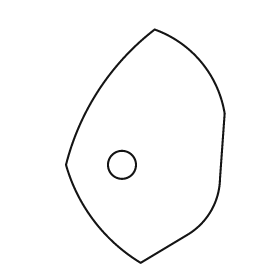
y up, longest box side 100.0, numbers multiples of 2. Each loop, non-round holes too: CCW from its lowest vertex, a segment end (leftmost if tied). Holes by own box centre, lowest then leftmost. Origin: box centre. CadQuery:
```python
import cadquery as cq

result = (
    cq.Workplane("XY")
    .moveTo(-2.0, -50.0)
    .lineTo(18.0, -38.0)
    .threePointArc((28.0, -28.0), (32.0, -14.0))
    .lineTo(34.0, 14.0)
    .threePointArc((24.0, 36.0), (4.0, 50.0))
    .threePointArc((-20.0, 24.0), (-34.0, -8.0))
    .threePointArc((-22.0, -32.0), (-2.0, -50.0))
    .close()
    .moveTo(-10.0, -8.0)
    .circle(6.0)
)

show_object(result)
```